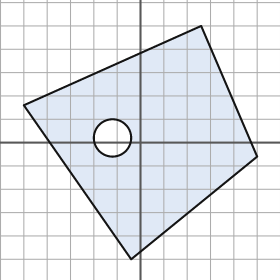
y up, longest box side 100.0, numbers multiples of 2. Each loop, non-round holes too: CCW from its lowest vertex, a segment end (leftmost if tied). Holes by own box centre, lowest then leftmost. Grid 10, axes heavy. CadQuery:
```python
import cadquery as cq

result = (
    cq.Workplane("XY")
    .moveTo(-4.0, -50.0)
    .lineTo(50.0, -6.0)
    .lineTo(26.0, 50.0)
    .lineTo(-50.0, 16.0)
    .close()
    .moveTo(-12.0, 2.0)
    .circle(8.0)
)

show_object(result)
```